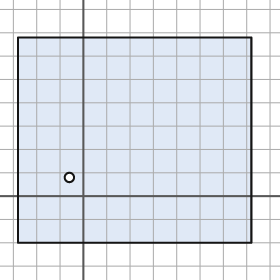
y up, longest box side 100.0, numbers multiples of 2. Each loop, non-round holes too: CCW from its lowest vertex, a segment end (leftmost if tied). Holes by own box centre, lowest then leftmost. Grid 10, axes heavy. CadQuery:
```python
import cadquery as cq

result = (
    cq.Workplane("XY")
    .moveTo(-28.0, -20.0)
    .lineTo(72.0, -20.0)
    .lineTo(72.0, 68.0)
    .lineTo(-28.0, 68.0)
    .close()
    .moveTo(-6.0, 8.0)
    .circle(2.0)
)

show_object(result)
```